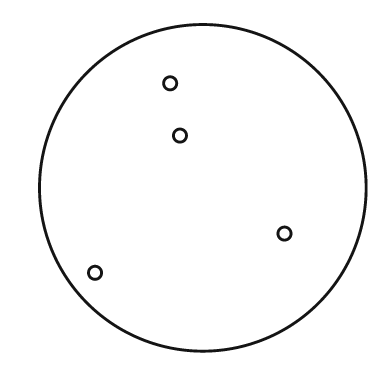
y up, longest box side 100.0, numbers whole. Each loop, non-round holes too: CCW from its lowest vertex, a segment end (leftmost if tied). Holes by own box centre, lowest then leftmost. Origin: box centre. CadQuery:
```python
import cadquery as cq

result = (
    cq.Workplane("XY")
    .moveTo(0.0, 0.0)
    .circle(50.0)
    .moveTo(-33.0, -26.0)
    .circle(2.0)
    .moveTo(25.0, -14.0)
    .circle(2.0)
    .moveTo(-7.0, 16.0)
    .circle(2.0)
    .moveTo(-10.0, 32.0)
    .circle(2.0)
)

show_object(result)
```